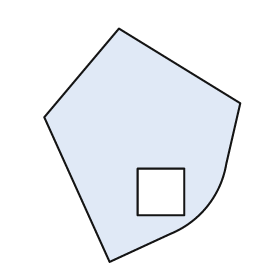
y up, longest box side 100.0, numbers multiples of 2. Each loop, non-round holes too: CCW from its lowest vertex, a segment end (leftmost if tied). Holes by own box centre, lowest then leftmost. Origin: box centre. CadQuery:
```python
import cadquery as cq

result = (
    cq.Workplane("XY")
    .moveTo(-14.0, -50.0)
    .lineTo(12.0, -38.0)
    .threePointArc((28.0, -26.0), (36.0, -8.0))
    .lineTo(42.0, 18.0)
    .lineTo(-10.0, 50.0)
    .lineTo(-42.0, 12.0)
    .close()
    .moveTo(-2.0, -30.0)
    .lineTo(18.0, -30.0)
    .lineTo(18.0, -10.0)
    .lineTo(-2.0, -10.0)
    .close()
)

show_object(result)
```